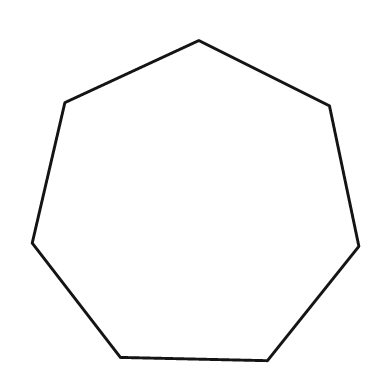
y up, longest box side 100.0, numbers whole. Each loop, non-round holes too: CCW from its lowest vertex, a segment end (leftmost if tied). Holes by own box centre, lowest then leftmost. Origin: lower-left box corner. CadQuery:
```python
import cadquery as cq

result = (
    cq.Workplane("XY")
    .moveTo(72.0, 0.0)
    .lineTo(100.0, 35.0)
    .lineTo(91.0, 78.0)
    .lineTo(51.0, 98.0)
    .lineTo(10.0, 79.0)
    .lineTo(0.0, 36.0)
    .lineTo(27.0, 1.0)
    .close()
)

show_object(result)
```